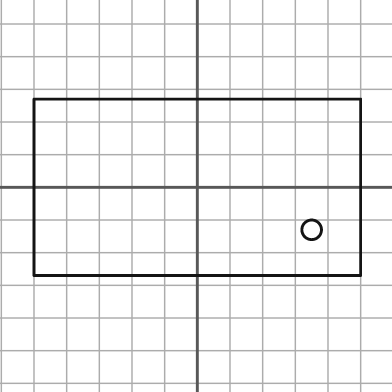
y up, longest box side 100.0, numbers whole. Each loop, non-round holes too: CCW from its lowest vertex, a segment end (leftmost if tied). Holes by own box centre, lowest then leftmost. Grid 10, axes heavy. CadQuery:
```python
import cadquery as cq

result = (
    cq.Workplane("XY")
    .moveTo(-50.0, -27.0)
    .lineTo(50.0, -27.0)
    .lineTo(50.0, 27.0)
    .lineTo(-50.0, 27.0)
    .close()
    .moveTo(35.0, -13.0)
    .circle(3.0)
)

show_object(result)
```